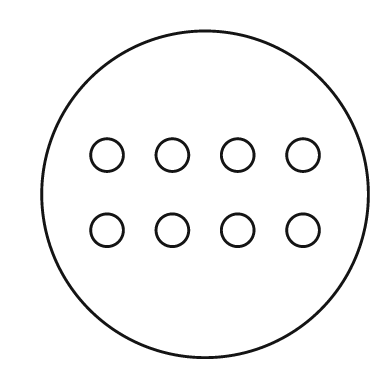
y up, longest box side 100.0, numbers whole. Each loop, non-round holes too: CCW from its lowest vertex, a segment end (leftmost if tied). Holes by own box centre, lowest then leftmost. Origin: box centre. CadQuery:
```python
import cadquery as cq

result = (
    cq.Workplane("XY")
    .moveTo(0.0, 0.0)
    .circle(50.0)
    .moveTo(-30.0, -11.0)
    .circle(5.0)
    .moveTo(-10.0, -11.0)
    .circle(5.0)
    .moveTo(10.0, -11.0)
    .circle(5.0)
    .moveTo(30.0, -11.0)
    .circle(5.0)
    .moveTo(-30.0, 12.0)
    .circle(5.0)
    .moveTo(-10.0, 12.0)
    .circle(5.0)
    .moveTo(10.0, 12.0)
    .circle(5.0)
    .moveTo(30.0, 12.0)
    .circle(5.0)
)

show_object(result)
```